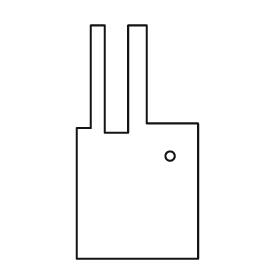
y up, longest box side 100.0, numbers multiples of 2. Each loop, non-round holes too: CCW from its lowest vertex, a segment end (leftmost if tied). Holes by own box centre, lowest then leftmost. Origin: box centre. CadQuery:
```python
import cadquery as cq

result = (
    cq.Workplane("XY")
    .moveTo(-26.0, -50.0)
    .lineTo(26.0, -50.0)
    .lineTo(26.0, 8.0)
    .lineTo(4.0, 8.0)
    .lineTo(4.0, 50.0)
    .lineTo(-4.0, 50.0)
    .lineTo(-4.0, 4.0)
    .lineTo(-14.0, 4.0)
    .lineTo(-14.0, 50.0)
    .lineTo(-20.0, 50.0)
    .lineTo(-20.0, 6.0)
    .lineTo(-26.0, 6.0)
    .close()
    .moveTo(14.0, -6.0)
    .circle(2.0)
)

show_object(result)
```